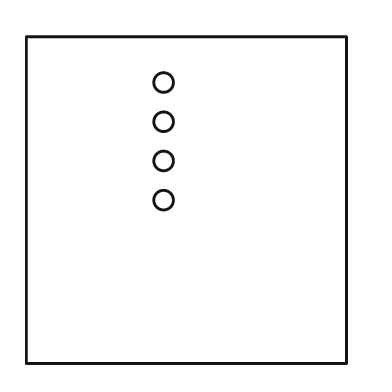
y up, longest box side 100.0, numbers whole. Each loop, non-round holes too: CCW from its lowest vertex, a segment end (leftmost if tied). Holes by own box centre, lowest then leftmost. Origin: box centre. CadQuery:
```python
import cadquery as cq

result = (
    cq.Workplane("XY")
    .moveTo(-49.0, -50.0)
    .lineTo(49.0, -50.0)
    .lineTo(49.0, 50.0)
    .lineTo(-49.0, 50.0)
    .close()
    .moveTo(-7.0, 0.0)
    .circle(3.0)
    .moveTo(-7.0, 12.0)
    .circle(3.0)
    .moveTo(-7.0, 24.0)
    .circle(3.0)
    .moveTo(-7.0, 36.0)
    .circle(3.0)
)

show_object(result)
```